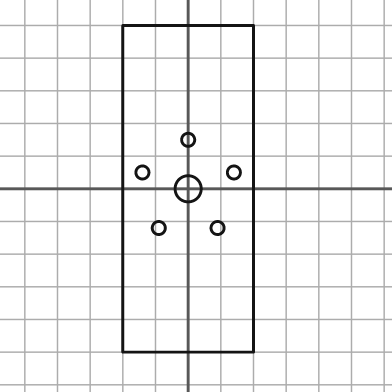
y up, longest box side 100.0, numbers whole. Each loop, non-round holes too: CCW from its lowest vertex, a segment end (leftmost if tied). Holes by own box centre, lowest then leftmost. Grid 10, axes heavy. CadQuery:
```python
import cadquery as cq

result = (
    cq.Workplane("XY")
    .moveTo(-20.0, -50.0)
    .lineTo(20.0, -50.0)
    .lineTo(20.0, 50.0)
    .lineTo(-20.0, 50.0)
    .close()
    .moveTo(-9.0, -12.0)
    .circle(2.0)
    .moveTo(9.0, -12.0)
    .circle(2.0)
    .moveTo(0.0, 0.0)
    .circle(4.0)
    .moveTo(-14.0, 5.0)
    .circle(2.0)
    .moveTo(14.0, 5.0)
    .circle(2.0)
    .moveTo(0.0, 15.0)
    .circle(2.0)
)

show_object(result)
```